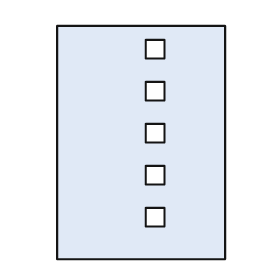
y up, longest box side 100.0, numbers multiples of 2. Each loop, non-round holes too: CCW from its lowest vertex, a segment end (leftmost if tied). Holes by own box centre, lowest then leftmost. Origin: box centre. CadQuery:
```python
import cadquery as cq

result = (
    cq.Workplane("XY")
    .moveTo(-36.0, -50.0)
    .lineTo(36.0, -50.0)
    .lineTo(36.0, 50.0)
    .lineTo(-36.0, 50.0)
    .close()
    .moveTo(2.0, -36.0)
    .lineTo(10.0, -36.0)
    .lineTo(10.0, -28.0)
    .lineTo(2.0, -28.0)
    .close()
    .moveTo(2.0, -18.0)
    .lineTo(10.0, -18.0)
    .lineTo(10.0, -10.0)
    .lineTo(2.0, -10.0)
    .close()
    .moveTo(2.0, 0.0)
    .lineTo(10.0, 0.0)
    .lineTo(10.0, 8.0)
    .lineTo(2.0, 8.0)
    .close()
    .moveTo(2.0, 18.0)
    .lineTo(10.0, 18.0)
    .lineTo(10.0, 26.0)
    .lineTo(2.0, 26.0)
    .close()
    .moveTo(2.0, 36.0)
    .lineTo(10.0, 36.0)
    .lineTo(10.0, 44.0)
    .lineTo(2.0, 44.0)
    .close()
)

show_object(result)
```